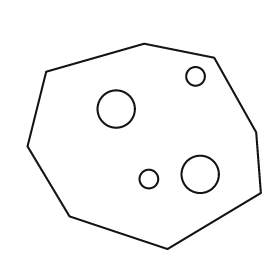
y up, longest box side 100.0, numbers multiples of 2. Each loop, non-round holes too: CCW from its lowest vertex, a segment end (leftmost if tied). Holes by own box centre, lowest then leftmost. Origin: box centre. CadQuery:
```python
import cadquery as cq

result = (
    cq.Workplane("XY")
    .moveTo(10.0, -44.0)
    .lineTo(50.0, -20.0)
    .lineTo(48.0, 6.0)
    .lineTo(30.0, 38.0)
    .lineTo(0.0, 44.0)
    .lineTo(-42.0, 32.0)
    .lineTo(-50.0, 0.0)
    .lineTo(-32.0, -30.0)
    .close()
    .moveTo(2.0, -14.0)
    .circle(4.0)
    .moveTo(24.0, -12.0)
    .circle(8.0)
    .moveTo(-12.0, 16.0)
    .circle(8.0)
    .moveTo(22.0, 30.0)
    .circle(4.0)
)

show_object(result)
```